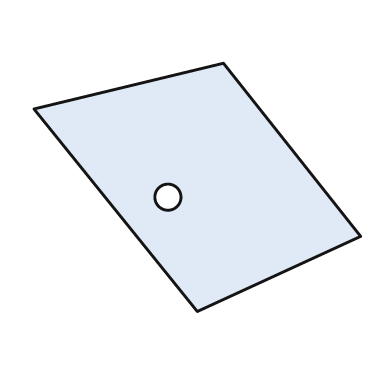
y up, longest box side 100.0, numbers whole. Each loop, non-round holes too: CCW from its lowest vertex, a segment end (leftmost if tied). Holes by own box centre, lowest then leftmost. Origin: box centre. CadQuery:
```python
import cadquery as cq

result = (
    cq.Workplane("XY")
    .moveTo(0.0, -38.0)
    .lineTo(50.0, -15.0)
    .lineTo(8.0, 38.0)
    .lineTo(-50.0, 24.0)
    .close()
    .moveTo(-9.0, -3.0)
    .circle(4.0)
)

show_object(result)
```